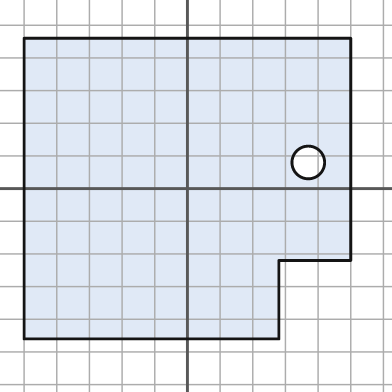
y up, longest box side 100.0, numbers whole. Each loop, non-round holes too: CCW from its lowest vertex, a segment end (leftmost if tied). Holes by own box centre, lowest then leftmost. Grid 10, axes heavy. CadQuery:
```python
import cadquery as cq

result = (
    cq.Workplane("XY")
    .moveTo(-50.0, -46.0)
    .lineTo(28.0, -46.0)
    .lineTo(28.0, -22.0)
    .lineTo(50.0, -22.0)
    .lineTo(50.0, 46.0)
    .lineTo(-50.0, 46.0)
    .close()
    .moveTo(37.0, 8.0)
    .circle(5.0)
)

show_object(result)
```